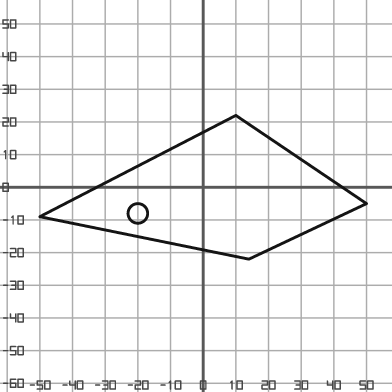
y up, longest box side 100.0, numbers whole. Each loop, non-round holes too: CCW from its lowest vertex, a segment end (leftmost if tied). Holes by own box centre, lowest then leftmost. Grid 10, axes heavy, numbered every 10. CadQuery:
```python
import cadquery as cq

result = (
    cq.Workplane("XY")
    .moveTo(14.0, -22.0)
    .lineTo(50.0, -5.0)
    .lineTo(10.0, 22.0)
    .lineTo(-50.0, -9.0)
    .close()
    .moveTo(-20.0, -8.0)
    .circle(3.0)
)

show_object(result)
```